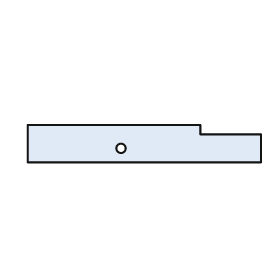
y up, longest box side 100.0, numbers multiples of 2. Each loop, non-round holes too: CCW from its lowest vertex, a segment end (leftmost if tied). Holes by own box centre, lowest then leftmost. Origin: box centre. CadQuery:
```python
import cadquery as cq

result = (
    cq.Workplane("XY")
    .moveTo(-50.0, -8.0)
    .lineTo(50.0, -8.0)
    .lineTo(50.0, 4.0)
    .lineTo(24.0, 4.0)
    .lineTo(24.0, 8.0)
    .lineTo(-50.0, 8.0)
    .close()
    .moveTo(-10.0, -2.0)
    .circle(2.0)
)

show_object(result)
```